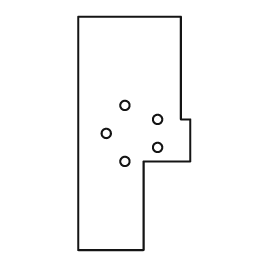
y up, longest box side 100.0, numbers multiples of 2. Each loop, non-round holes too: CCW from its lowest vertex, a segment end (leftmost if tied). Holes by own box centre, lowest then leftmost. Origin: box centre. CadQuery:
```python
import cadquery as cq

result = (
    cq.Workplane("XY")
    .moveTo(-24.0, -50.0)
    .lineTo(4.0, -50.0)
    .lineTo(4.0, -12.0)
    .lineTo(24.0, -12.0)
    .lineTo(24.0, 6.0)
    .lineTo(20.0, 6.0)
    .lineTo(20.0, 50.0)
    .lineTo(-24.0, 50.0)
    .close()
    .moveTo(-4.0, -12.0)
    .circle(2.0)
    .moveTo(10.0, -6.0)
    .circle(2.0)
    .moveTo(-12.0, 0.0)
    .circle(2.0)
    .moveTo(10.0, 6.0)
    .circle(2.0)
    .moveTo(-4.0, 12.0)
    .circle(2.0)
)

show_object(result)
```